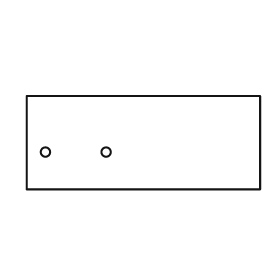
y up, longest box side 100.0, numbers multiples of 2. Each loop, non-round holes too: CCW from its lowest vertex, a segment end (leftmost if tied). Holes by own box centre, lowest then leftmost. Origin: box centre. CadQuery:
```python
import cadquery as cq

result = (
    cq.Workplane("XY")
    .moveTo(-50.0, -20.0)
    .lineTo(50.0, -20.0)
    .lineTo(50.0, 20.0)
    .lineTo(-50.0, 20.0)
    .close()
    .moveTo(-42.0, -4.0)
    .circle(2.0)
    .moveTo(-16.0, -4.0)
    .circle(2.0)
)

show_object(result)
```